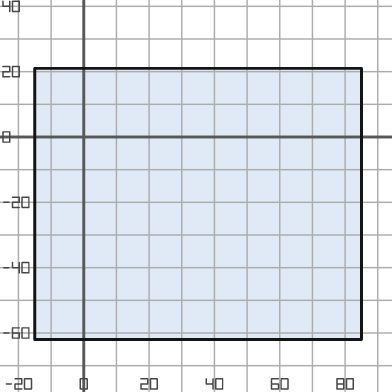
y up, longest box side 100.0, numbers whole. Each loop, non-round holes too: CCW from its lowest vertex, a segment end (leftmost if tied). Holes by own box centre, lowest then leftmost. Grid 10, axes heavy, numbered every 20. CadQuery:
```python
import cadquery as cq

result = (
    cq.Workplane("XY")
    .moveTo(-15.0, -62.0)
    .lineTo(85.0, -62.0)
    .lineTo(85.0, 21.0)
    .lineTo(-15.0, 21.0)
    .close()
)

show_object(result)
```